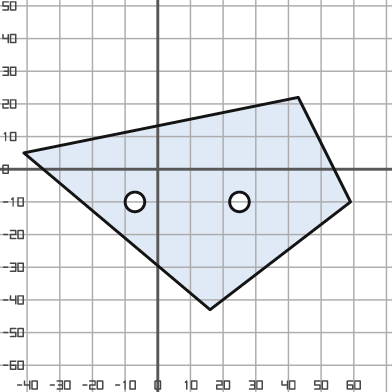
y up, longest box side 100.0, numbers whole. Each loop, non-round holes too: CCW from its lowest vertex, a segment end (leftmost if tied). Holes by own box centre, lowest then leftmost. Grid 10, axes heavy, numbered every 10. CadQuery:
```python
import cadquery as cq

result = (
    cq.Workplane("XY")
    .moveTo(16.0, -43.0)
    .lineTo(59.0, -10.0)
    .lineTo(43.0, 22.0)
    .lineTo(-41.0, 5.0)
    .close()
    .moveTo(-7.0, -10.0)
    .circle(3.0)
    .moveTo(25.0, -10.0)
    .circle(3.0)
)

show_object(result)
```